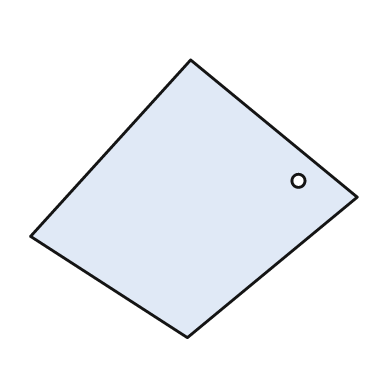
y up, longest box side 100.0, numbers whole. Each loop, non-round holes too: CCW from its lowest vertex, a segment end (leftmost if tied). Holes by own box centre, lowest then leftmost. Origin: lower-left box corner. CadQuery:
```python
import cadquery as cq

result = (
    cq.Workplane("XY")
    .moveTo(48.0, 0.0)
    .lineTo(100.0, 43.0)
    .lineTo(49.0, 85.0)
    .lineTo(0.0, 31.0)
    .close()
    .moveTo(82.0, 48.0)
    .circle(2.0)
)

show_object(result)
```